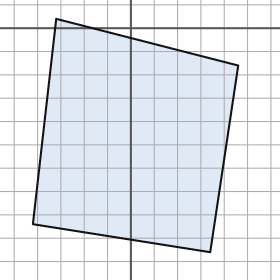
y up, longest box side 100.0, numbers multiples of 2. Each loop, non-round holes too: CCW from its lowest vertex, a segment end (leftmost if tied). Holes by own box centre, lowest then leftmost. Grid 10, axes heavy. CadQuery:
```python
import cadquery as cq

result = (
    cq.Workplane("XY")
    .moveTo(34.0, -96.0)
    .lineTo(46.0, -16.0)
    .lineTo(-32.0, 4.0)
    .lineTo(-42.0, -84.0)
    .close()
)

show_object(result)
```